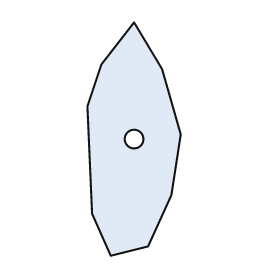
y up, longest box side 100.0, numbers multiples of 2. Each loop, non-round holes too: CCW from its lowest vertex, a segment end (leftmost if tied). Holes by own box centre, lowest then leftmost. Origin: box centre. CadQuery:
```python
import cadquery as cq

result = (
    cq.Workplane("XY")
    .moveTo(-10.0, -50.0)
    .lineTo(6.0, -46.0)
    .lineTo(16.0, -24.0)
    .lineTo(20.0, 2.0)
    .lineTo(12.0, 30.0)
    .lineTo(0.0, 50.0)
    .lineTo(-14.0, 32.0)
    .lineTo(-20.0, 14.0)
    .lineTo(-18.0, -32.0)
    .close()
    .moveTo(0.0, 0.0)
    .circle(4.0)
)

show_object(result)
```